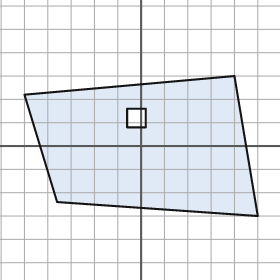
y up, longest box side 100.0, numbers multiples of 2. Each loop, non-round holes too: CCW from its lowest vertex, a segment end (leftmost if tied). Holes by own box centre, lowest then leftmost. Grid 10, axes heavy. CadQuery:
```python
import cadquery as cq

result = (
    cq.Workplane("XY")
    .moveTo(50.0, -30.0)
    .lineTo(40.0, 30.0)
    .lineTo(-50.0, 22.0)
    .lineTo(-36.0, -24.0)
    .close()
    .moveTo(-6.0, 8.0)
    .lineTo(2.0, 8.0)
    .lineTo(2.0, 16.0)
    .lineTo(-6.0, 16.0)
    .close()
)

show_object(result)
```